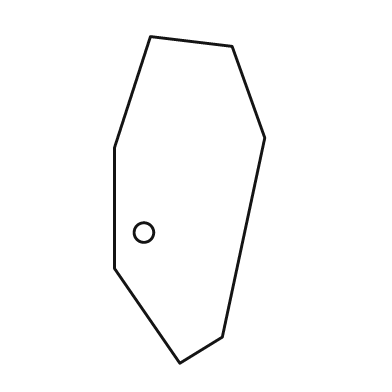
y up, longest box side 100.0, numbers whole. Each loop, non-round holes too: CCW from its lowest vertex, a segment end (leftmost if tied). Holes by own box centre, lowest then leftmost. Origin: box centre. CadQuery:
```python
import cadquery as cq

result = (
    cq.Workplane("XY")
    .moveTo(-3.0, -50.0)
    .lineTo(10.0, -42.0)
    .lineTo(23.0, 19.0)
    .lineTo(13.0, 47.0)
    .lineTo(-12.0, 50.0)
    .lineTo(-23.0, 16.0)
    .lineTo(-23.0, -21.0)
    .close()
    .moveTo(-14.0, -10.0)
    .circle(3.0)
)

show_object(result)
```